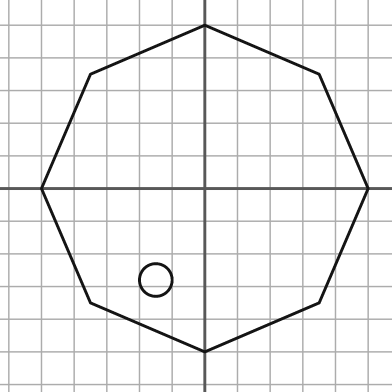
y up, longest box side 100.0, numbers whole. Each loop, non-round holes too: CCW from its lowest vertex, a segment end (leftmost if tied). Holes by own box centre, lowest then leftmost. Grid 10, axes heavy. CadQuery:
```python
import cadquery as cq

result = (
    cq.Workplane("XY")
    .moveTo(0.0, -50.0)
    .lineTo(35.0, -35.0)
    .lineTo(50.0, 0.0)
    .lineTo(35.0, 35.0)
    .lineTo(0.0, 50.0)
    .lineTo(-35.0, 35.0)
    .lineTo(-50.0, 0.0)
    .lineTo(-35.0, -35.0)
    .close()
    .moveTo(-15.0, -28.0)
    .circle(5.0)
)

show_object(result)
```